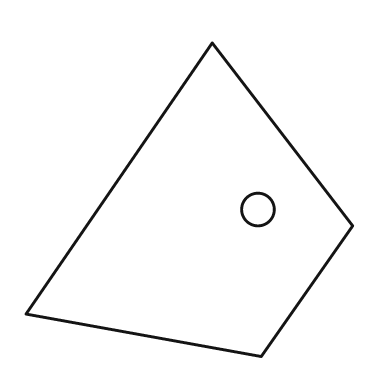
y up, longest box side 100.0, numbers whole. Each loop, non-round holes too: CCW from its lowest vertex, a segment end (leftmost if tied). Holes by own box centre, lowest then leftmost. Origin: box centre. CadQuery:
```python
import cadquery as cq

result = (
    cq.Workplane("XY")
    .moveTo(22.0, -48.0)
    .lineTo(50.0, -8.0)
    .lineTo(7.0, 48.0)
    .lineTo(-50.0, -35.0)
    .close()
    .moveTo(21.0, -3.0)
    .circle(5.0)
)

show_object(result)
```